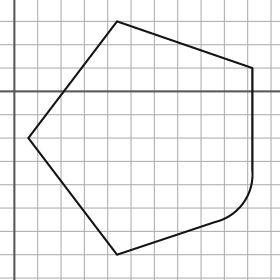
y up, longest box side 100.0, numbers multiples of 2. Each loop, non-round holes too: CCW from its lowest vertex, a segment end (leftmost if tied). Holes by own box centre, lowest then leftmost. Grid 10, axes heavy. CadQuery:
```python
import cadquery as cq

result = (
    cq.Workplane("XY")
    .moveTo(44.0, -70.0)
    .lineTo(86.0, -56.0)
    .threePointArc((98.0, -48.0), (102.0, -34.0))
    .lineTo(102.0, 10.0)
    .lineTo(44.0, 30.0)
    .lineTo(6.0, -20.0)
    .close()
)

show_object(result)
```